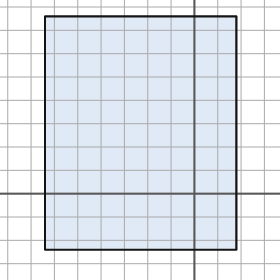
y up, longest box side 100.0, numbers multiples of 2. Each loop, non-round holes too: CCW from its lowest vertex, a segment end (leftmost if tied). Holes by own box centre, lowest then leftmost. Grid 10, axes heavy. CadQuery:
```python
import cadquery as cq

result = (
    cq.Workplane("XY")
    .moveTo(-64.0, -24.0)
    .lineTo(18.0, -24.0)
    .lineTo(18.0, 76.0)
    .lineTo(-64.0, 76.0)
    .close()
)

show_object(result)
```